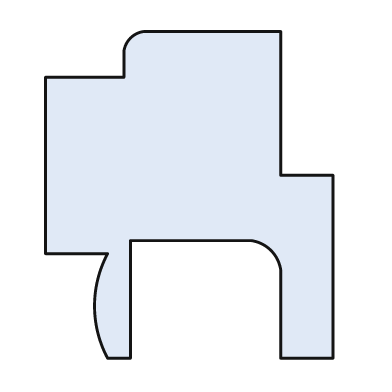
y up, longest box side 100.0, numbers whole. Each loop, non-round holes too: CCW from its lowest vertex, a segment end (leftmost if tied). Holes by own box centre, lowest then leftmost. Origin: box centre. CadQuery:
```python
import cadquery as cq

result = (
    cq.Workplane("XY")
    .moveTo(-25.0, -50.0)
    .lineTo(-18.0, -50.0)
    .lineTo(-18.0, -14.0)
    .lineTo(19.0, -14.0)
    .threePointArc((25.0, -17.0), (28.0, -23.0))
    .lineTo(28.0, -50.0)
    .lineTo(44.0, -50.0)
    .lineTo(44.0, 6.0)
    .lineTo(28.0, 6.0)
    .lineTo(28.0, 50.0)
    .lineTo(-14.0, 50.0)
    .threePointArc((-18.0, 48.0), (-20.0, 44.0))
    .lineTo(-20.0, 36.0)
    .lineTo(-44.0, 36.0)
    .lineTo(-44.0, -18.0)
    .lineTo(-25.0, -18.0)
    .threePointArc((-29.0, -34.0), (-25.0, -50.0))
    .close()
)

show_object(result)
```